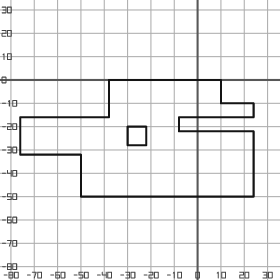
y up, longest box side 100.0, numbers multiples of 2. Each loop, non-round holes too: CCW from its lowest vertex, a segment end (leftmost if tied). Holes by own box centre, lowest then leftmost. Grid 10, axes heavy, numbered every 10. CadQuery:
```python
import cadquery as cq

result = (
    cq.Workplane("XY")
    .moveTo(-50.0, -50.0)
    .lineTo(24.0, -50.0)
    .lineTo(24.0, -22.0)
    .lineTo(-8.0, -22.0)
    .lineTo(-8.0, -16.0)
    .lineTo(24.0, -16.0)
    .lineTo(24.0, -10.0)
    .lineTo(10.0, -10.0)
    .lineTo(10.0, 0.0)
    .lineTo(-38.0, 0.0)
    .lineTo(-38.0, -16.0)
    .lineTo(-76.0, -16.0)
    .lineTo(-76.0, -32.0)
    .lineTo(-50.0, -32.0)
    .close()
    .moveTo(-30.0, -28.0)
    .lineTo(-22.0, -28.0)
    .lineTo(-22.0, -20.0)
    .lineTo(-30.0, -20.0)
    .close()
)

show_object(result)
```